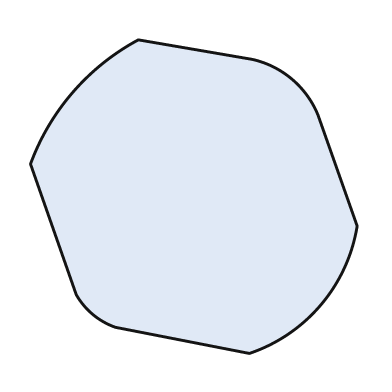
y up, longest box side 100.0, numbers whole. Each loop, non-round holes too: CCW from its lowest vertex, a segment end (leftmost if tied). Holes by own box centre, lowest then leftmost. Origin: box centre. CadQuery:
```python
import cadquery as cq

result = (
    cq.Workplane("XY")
    .moveTo(17.0, -48.0)
    .threePointArc((39.0, -33.0), (50.0, -9.0))
    .lineTo(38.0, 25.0)
    .threePointArc((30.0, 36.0), (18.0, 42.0))
    .lineTo(-17.0, 48.0)
    .threePointArc((-37.0, 32.0), (-50.0, 10.0))
    .lineTo(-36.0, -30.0)
    .threePointArc((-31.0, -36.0), (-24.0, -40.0))
    .close()
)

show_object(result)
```